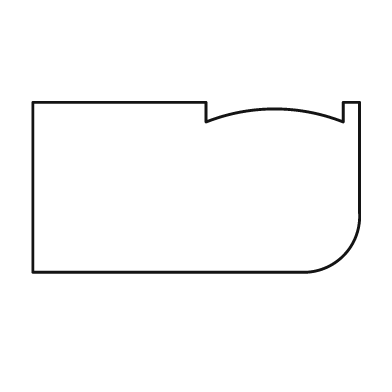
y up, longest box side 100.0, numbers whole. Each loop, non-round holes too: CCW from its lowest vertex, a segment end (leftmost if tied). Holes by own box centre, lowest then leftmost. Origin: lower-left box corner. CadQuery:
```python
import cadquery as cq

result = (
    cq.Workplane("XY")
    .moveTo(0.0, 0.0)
    .lineTo(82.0, 0.0)
    .threePointArc((95.0, 5.0), (100.0, 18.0))
    .lineTo(100.0, 52.0)
    .lineTo(95.0, 52.0)
    .lineTo(95.0, 46.0)
    .threePointArc((74.0, 50.0), (53.0, 46.0))
    .lineTo(53.0, 52.0)
    .lineTo(0.0, 52.0)
    .close()
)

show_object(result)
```